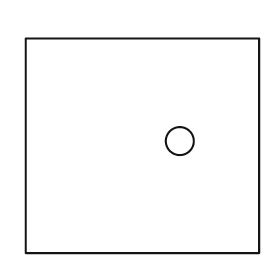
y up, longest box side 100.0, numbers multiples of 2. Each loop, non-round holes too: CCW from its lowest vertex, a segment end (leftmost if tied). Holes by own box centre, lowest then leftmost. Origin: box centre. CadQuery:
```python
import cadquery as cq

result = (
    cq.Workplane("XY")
    .moveTo(-50.0, -46.0)
    .lineTo(50.0, -46.0)
    .lineTo(50.0, 46.0)
    .lineTo(-50.0, 46.0)
    .close()
    .moveTo(16.0, 2.0)
    .circle(6.0)
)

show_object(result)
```